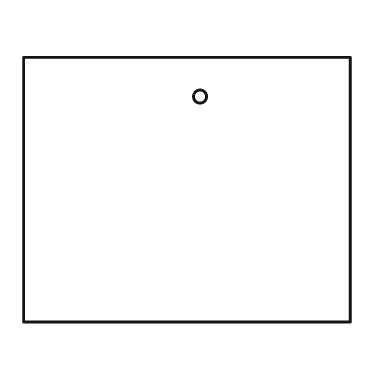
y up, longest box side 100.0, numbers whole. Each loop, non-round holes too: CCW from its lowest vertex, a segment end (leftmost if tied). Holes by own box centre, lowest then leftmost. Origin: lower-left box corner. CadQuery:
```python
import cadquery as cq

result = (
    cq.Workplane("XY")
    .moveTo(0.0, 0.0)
    .lineTo(100.0, 0.0)
    .lineTo(100.0, 81.0)
    .lineTo(0.0, 81.0)
    .close()
    .moveTo(54.0, 69.0)
    .circle(2.0)
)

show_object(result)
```